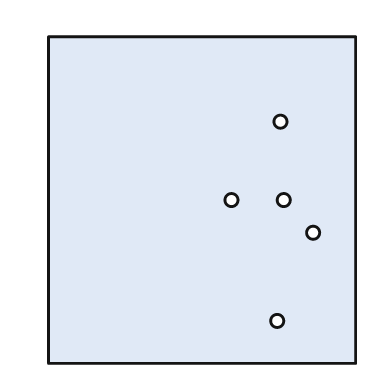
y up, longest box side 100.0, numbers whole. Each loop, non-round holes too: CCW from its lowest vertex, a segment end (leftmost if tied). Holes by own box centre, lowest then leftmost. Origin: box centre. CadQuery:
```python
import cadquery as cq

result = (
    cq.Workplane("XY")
    .moveTo(-47.0, -50.0)
    .lineTo(47.0, -50.0)
    .lineTo(47.0, 50.0)
    .lineTo(-47.0, 50.0)
    .close()
    .moveTo(23.0, -37.0)
    .circle(2.0)
    .moveTo(34.0, -10.0)
    .circle(2.0)
    .moveTo(9.0, 0.0)
    .circle(2.0)
    .moveTo(25.0, 0.0)
    .circle(2.0)
    .moveTo(24.0, 24.0)
    .circle(2.0)
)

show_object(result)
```